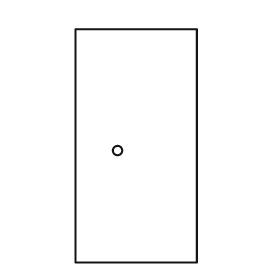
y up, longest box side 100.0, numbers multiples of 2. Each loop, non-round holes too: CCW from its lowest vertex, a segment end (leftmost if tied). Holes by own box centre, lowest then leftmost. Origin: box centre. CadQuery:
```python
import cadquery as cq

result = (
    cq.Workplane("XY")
    .moveTo(-26.0, -50.0)
    .lineTo(26.0, -50.0)
    .lineTo(26.0, 50.0)
    .lineTo(-26.0, 50.0)
    .close()
    .moveTo(-8.0, -2.0)
    .circle(2.0)
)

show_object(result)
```